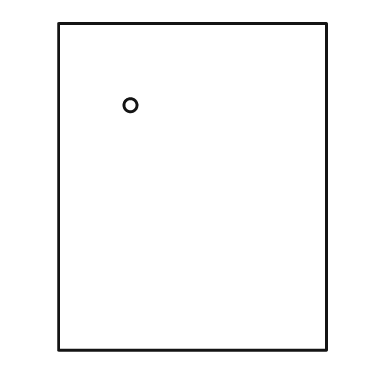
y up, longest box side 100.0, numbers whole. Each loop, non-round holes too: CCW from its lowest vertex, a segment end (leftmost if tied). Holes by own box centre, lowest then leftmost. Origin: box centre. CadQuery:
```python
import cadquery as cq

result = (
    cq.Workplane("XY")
    .moveTo(-41.0, -50.0)
    .lineTo(41.0, -50.0)
    .lineTo(41.0, 50.0)
    .lineTo(-41.0, 50.0)
    .close()
    .moveTo(-19.0, 25.0)
    .circle(2.0)
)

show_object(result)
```